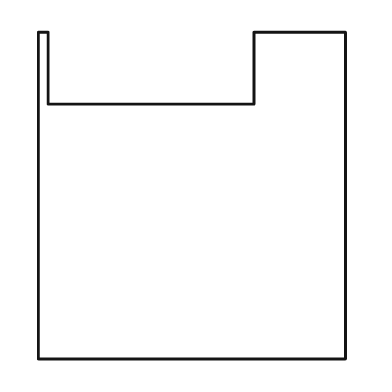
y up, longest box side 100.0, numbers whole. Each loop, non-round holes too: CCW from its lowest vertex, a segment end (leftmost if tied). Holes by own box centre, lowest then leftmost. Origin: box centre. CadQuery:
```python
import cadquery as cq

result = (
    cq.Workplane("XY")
    .moveTo(-47.0, -50.0)
    .lineTo(47.0, -50.0)
    .lineTo(47.0, 50.0)
    .lineTo(19.0, 50.0)
    .lineTo(19.0, 28.0)
    .lineTo(-44.0, 28.0)
    .lineTo(-44.0, 50.0)
    .lineTo(-47.0, 50.0)
    .close()
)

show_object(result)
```